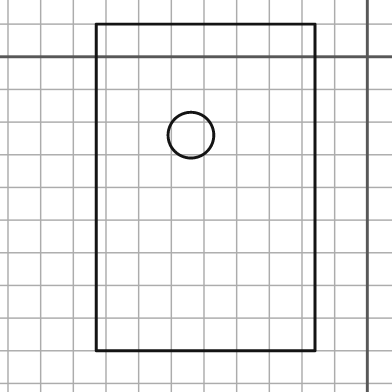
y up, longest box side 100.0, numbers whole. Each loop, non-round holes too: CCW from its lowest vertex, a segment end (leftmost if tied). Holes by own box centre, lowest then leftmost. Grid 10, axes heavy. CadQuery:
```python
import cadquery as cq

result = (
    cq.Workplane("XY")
    .moveTo(-83.0, -90.0)
    .lineTo(-16.0, -90.0)
    .lineTo(-16.0, 10.0)
    .lineTo(-83.0, 10.0)
    .close()
    .moveTo(-54.0, -24.0)
    .circle(7.0)
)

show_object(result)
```